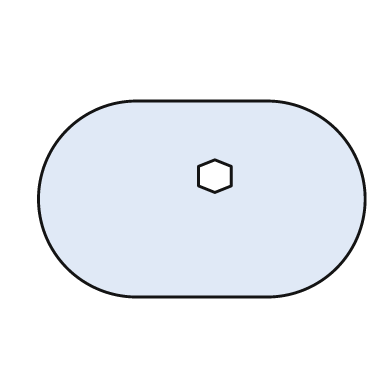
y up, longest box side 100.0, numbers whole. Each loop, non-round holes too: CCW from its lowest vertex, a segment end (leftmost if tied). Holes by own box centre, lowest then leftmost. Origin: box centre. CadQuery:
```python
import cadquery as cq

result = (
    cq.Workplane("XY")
    .moveTo(-20.0, -30.0)
    .lineTo(20.0, -30.0)
    .threePointArc((50.0, 0.0), (20.0, 30.0))
    .lineTo(-20.0, 30.0)
    .threePointArc((-50.0, 0.0), (-20.0, -30.0))
    .close()
    .moveTo(4.0, 2.0)
    .lineTo(9.0, 4.0)
    .lineTo(9.0, 10.0)
    .lineTo(4.0, 12.0)
    .lineTo(-1.0, 10.0)
    .lineTo(-1.0, 4.0)
    .close()
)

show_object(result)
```